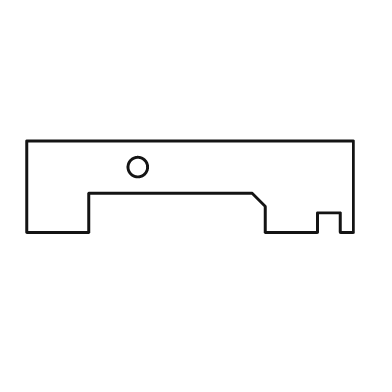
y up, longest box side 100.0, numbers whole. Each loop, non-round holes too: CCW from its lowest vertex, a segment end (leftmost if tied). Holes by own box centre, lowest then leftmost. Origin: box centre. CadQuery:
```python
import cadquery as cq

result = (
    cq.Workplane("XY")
    .moveTo(-50.0, -14.0)
    .lineTo(-31.0, -14.0)
    .lineTo(-31.0, -2.0)
    .lineTo(19.0, -2.0)
    .lineTo(23.0, -6.0)
    .lineTo(23.0, -14.0)
    .lineTo(39.0, -14.0)
    .lineTo(39.0, -8.0)
    .lineTo(46.0, -8.0)
    .lineTo(46.0, -14.0)
    .lineTo(50.0, -14.0)
    .lineTo(50.0, 14.0)
    .lineTo(-50.0, 14.0)
    .close()
    .moveTo(-16.0, 6.0)
    .circle(3.0)
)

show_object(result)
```